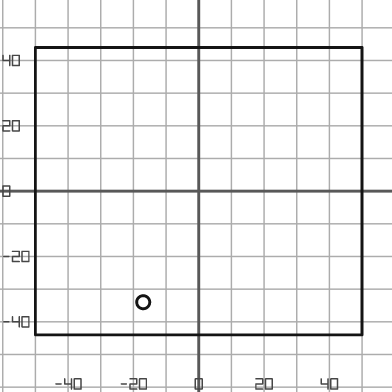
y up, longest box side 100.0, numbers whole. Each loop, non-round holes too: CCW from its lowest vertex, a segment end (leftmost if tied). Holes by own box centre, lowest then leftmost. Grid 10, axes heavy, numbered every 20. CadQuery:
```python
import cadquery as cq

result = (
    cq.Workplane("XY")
    .moveTo(-50.0, -44.0)
    .lineTo(50.0, -44.0)
    .lineTo(50.0, 44.0)
    .lineTo(-50.0, 44.0)
    .close()
    .moveTo(-17.0, -34.0)
    .circle(2.0)
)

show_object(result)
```